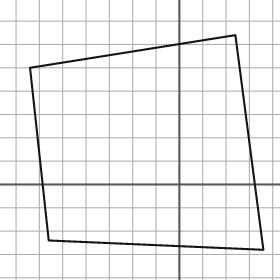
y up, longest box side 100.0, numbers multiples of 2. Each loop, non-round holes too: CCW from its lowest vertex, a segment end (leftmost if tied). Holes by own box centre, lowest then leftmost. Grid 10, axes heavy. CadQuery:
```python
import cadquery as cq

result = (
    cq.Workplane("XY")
    .moveTo(36.0, -28.0)
    .lineTo(24.0, 64.0)
    .lineTo(-64.0, 50.0)
    .lineTo(-56.0, -24.0)
    .close()
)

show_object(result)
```